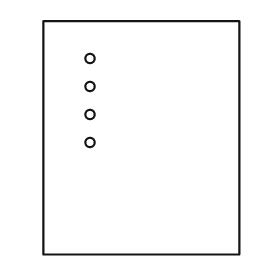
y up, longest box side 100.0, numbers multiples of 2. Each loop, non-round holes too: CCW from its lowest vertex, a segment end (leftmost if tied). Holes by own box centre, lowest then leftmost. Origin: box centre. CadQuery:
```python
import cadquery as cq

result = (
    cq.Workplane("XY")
    .moveTo(-42.0, -50.0)
    .lineTo(42.0, -50.0)
    .lineTo(42.0, 50.0)
    .lineTo(-42.0, 50.0)
    .close()
    .moveTo(-22.0, -2.0)
    .circle(2.0)
    .moveTo(-22.0, 10.0)
    .circle(2.0)
    .moveTo(-22.0, 22.0)
    .circle(2.0)
    .moveTo(-22.0, 34.0)
    .circle(2.0)
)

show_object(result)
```